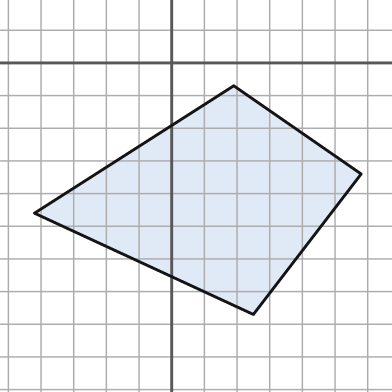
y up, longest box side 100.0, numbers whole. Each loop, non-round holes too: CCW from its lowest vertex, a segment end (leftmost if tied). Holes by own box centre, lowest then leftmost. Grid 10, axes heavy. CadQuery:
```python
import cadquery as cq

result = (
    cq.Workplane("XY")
    .moveTo(25.0, -77.0)
    .lineTo(58.0, -34.0)
    .lineTo(19.0, -7.0)
    .lineTo(-42.0, -46.0)
    .close()
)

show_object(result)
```